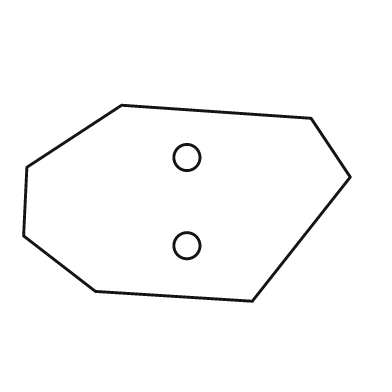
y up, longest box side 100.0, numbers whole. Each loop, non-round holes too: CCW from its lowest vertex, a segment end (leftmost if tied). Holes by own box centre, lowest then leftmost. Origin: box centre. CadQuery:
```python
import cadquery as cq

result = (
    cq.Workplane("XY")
    .moveTo(20.0, -30.0)
    .lineTo(50.0, 8.0)
    .lineTo(38.0, 26.0)
    .lineTo(-20.0, 30.0)
    .lineTo(-49.0, 11.0)
    .lineTo(-50.0, -10.0)
    .lineTo(-28.0, -27.0)
    .close()
    .moveTo(0.0, -13.0)
    .circle(4.0)
    .moveTo(0.0, 14.0)
    .circle(4.0)
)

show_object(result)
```